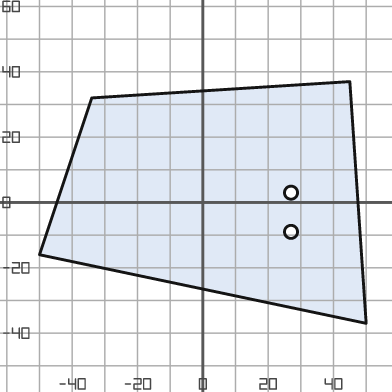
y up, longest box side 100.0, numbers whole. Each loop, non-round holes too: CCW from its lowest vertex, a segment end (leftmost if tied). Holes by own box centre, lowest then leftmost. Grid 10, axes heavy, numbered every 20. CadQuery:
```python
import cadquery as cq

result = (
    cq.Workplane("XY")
    .moveTo(50.0, -37.0)
    .lineTo(45.0, 37.0)
    .lineTo(-34.0, 32.0)
    .lineTo(-50.0, -16.0)
    .close()
    .moveTo(27.0, -9.0)
    .circle(2.0)
    .moveTo(27.0, 3.0)
    .circle(2.0)
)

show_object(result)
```